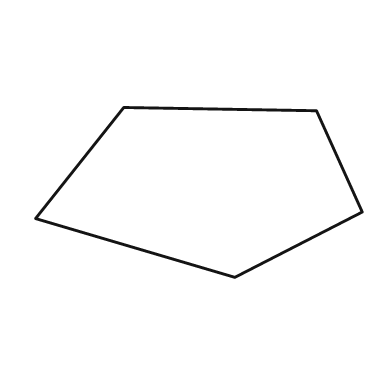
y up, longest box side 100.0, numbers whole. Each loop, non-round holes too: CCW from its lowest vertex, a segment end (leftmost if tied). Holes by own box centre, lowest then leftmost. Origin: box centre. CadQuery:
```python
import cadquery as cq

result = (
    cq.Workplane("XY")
    .moveTo(11.0, -26.0)
    .lineTo(50.0, -6.0)
    .lineTo(36.0, 25.0)
    .lineTo(-23.0, 26.0)
    .lineTo(-50.0, -8.0)
    .close()
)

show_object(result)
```